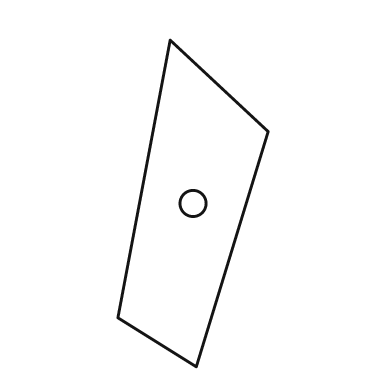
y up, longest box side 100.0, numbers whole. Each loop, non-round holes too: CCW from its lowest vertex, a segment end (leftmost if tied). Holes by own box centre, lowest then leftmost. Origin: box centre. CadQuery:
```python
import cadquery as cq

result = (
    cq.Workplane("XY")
    .moveTo(1.0, -50.0)
    .lineTo(23.0, 22.0)
    .lineTo(-7.0, 50.0)
    .lineTo(-23.0, -35.0)
    .close()
    .moveTo(0.0, 0.0)
    .circle(4.0)
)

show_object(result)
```